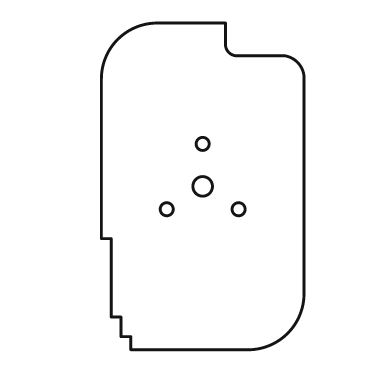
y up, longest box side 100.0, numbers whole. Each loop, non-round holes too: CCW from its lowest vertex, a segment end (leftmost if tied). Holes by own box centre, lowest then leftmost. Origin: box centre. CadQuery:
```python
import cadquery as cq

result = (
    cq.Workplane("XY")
    .moveTo(-22.0, -50.0)
    .lineTo(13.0, -50.0)
    .threePointArc((26.0, -45.0), (31.0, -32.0))
    .lineTo(31.0, 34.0)
    .threePointArc((29.0, 38.0), (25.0, 40.0))
    .lineTo(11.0, 40.0)
    .threePointArc((8.0, 41.0), (7.0, 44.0))
    .lineTo(7.0, 50.0)
    .lineTo(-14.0, 50.0)
    .threePointArc((-26.0, 45.0), (-31.0, 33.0))
    .lineTo(-31.0, -16.0)
    .lineTo(-28.0, -16.0)
    .lineTo(-28.0, -40.0)
    .lineTo(-25.0, -40.0)
    .lineTo(-25.0, -46.0)
    .lineTo(-22.0, -46.0)
    .close()
    .moveTo(-11.0, -7.0)
    .circle(2.0)
    .moveTo(11.0, -7.0)
    .circle(2.0)
    .moveTo(0.0, 0.0)
    .circle(3.0)
    .moveTo(0.0, 13.0)
    .circle(2.0)
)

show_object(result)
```